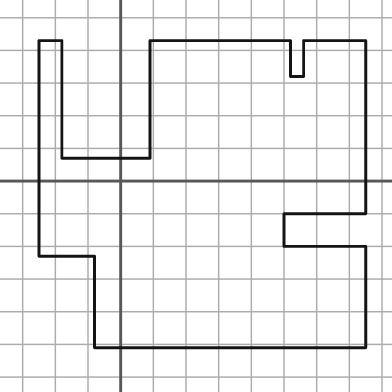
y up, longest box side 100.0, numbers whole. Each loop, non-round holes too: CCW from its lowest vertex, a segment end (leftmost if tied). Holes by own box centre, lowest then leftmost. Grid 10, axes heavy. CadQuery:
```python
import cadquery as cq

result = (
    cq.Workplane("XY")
    .moveTo(-8.0, -51.0)
    .lineTo(75.0, -51.0)
    .lineTo(75.0, -20.0)
    .lineTo(50.0, -20.0)
    .lineTo(50.0, -10.0)
    .lineTo(75.0, -10.0)
    .lineTo(75.0, 43.0)
    .lineTo(56.0, 43.0)
    .lineTo(56.0, 32.0)
    .lineTo(52.0, 32.0)
    .lineTo(52.0, 43.0)
    .lineTo(9.0, 43.0)
    .lineTo(9.0, 7.0)
    .lineTo(-18.0, 7.0)
    .lineTo(-18.0, 43.0)
    .lineTo(-25.0, 43.0)
    .lineTo(-25.0, -23.0)
    .lineTo(-8.0, -23.0)
    .close()
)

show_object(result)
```